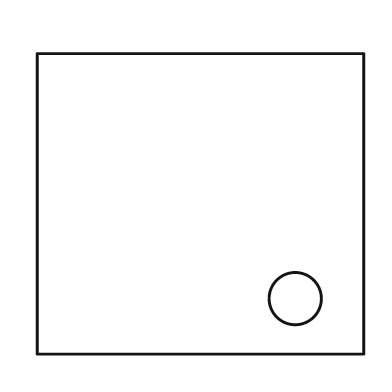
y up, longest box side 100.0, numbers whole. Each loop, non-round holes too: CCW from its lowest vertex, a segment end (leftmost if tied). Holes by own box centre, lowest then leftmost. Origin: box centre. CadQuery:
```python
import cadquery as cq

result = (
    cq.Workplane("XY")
    .moveTo(-50.0, -46.0)
    .lineTo(50.0, -46.0)
    .lineTo(50.0, 46.0)
    .lineTo(-50.0, 46.0)
    .close()
    .moveTo(29.0, -29.0)
    .circle(8.0)
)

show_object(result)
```